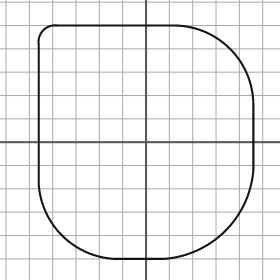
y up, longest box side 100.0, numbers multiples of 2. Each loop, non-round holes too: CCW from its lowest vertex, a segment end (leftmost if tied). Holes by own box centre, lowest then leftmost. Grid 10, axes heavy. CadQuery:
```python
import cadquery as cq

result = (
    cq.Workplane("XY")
    .moveTo(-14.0, -50.0)
    .lineTo(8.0, -50.0)
    .threePointArc((34.0, -38.0), (46.0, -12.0))
    .lineTo(46.0, 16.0)
    .threePointArc((36.0, 40.0), (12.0, 50.0))
    .lineTo(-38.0, 50.0)
    .threePointArc((-44.0, 48.0), (-46.0, 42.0))
    .lineTo(-46.0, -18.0)
    .threePointArc((-36.0, -40.0), (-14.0, -50.0))
    .close()
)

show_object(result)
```